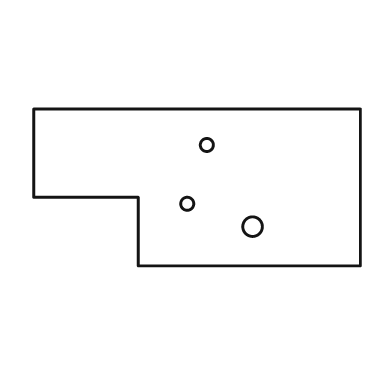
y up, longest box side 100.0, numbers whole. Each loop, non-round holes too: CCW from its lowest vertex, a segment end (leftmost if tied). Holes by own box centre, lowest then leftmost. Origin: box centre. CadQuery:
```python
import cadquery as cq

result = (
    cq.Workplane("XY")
    .moveTo(-18.0, -24.0)
    .lineTo(50.0, -24.0)
    .lineTo(50.0, 24.0)
    .lineTo(-50.0, 24.0)
    .lineTo(-50.0, -3.0)
    .lineTo(-18.0, -3.0)
    .close()
    .moveTo(17.0, -12.0)
    .circle(3.0)
    .moveTo(-3.0, -5.0)
    .circle(2.0)
    .moveTo(3.0, 13.0)
    .circle(2.0)
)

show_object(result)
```